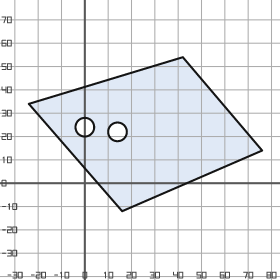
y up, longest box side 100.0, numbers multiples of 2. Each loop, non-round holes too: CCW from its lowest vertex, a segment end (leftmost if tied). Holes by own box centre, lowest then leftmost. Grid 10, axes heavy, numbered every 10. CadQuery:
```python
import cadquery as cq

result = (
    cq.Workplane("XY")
    .moveTo(16.0, -12.0)
    .lineTo(76.0, 14.0)
    .lineTo(42.0, 54.0)
    .lineTo(-24.0, 34.0)
    .close()
    .moveTo(14.0, 22.0)
    .circle(4.0)
    .moveTo(0.0, 24.0)
    .circle(4.0)
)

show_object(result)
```